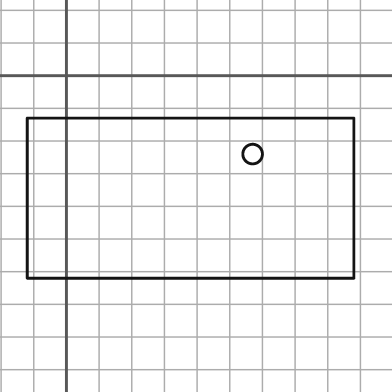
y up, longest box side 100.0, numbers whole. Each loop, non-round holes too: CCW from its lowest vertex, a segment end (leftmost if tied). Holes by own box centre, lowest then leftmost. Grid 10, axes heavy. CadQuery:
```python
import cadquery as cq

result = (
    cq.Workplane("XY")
    .moveTo(-12.0, -62.0)
    .lineTo(88.0, -62.0)
    .lineTo(88.0, -13.0)
    .lineTo(-12.0, -13.0)
    .close()
    .moveTo(57.0, -24.0)
    .circle(3.0)
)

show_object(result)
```